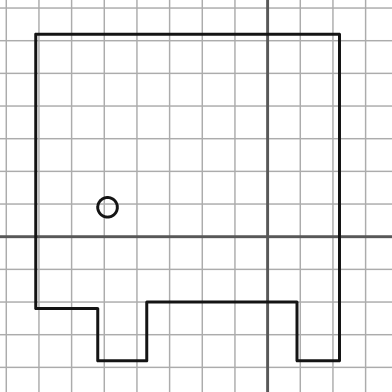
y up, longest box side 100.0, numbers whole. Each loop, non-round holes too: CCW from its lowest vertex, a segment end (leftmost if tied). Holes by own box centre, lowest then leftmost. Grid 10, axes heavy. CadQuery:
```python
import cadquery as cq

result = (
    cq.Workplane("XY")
    .moveTo(-52.0, -38.0)
    .lineTo(-37.0, -38.0)
    .lineTo(-37.0, -20.0)
    .lineTo(9.0, -20.0)
    .lineTo(9.0, -38.0)
    .lineTo(22.0, -38.0)
    .lineTo(22.0, 62.0)
    .lineTo(-71.0, 62.0)
    .lineTo(-71.0, -22.0)
    .lineTo(-52.0, -22.0)
    .close()
    .moveTo(-49.0, 9.0)
    .circle(3.0)
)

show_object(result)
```